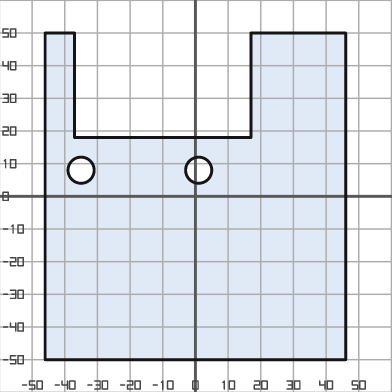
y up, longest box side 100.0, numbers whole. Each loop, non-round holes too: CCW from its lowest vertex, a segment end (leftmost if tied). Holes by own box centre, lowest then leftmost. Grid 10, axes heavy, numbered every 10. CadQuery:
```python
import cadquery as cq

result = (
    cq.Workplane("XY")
    .moveTo(-46.0, -50.0)
    .lineTo(46.0, -50.0)
    .lineTo(46.0, 50.0)
    .lineTo(17.0, 50.0)
    .lineTo(17.0, 18.0)
    .lineTo(-37.0, 18.0)
    .lineTo(-37.0, 50.0)
    .lineTo(-46.0, 50.0)
    .close()
    .moveTo(-35.0, 8.0)
    .circle(4.0)
    .moveTo(1.0, 8.0)
    .circle(4.0)
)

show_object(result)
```